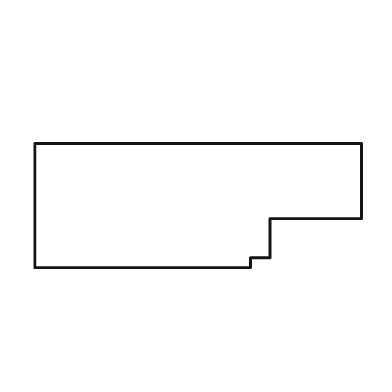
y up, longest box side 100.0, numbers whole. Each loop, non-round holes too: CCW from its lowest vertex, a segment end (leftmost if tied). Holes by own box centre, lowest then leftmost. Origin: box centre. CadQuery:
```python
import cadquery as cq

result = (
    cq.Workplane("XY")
    .moveTo(-50.0, -19.0)
    .lineTo(16.0, -19.0)
    .lineTo(16.0, -16.0)
    .lineTo(22.0, -16.0)
    .lineTo(22.0, -4.0)
    .lineTo(50.0, -4.0)
    .lineTo(50.0, 19.0)
    .lineTo(-50.0, 19.0)
    .close()
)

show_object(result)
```